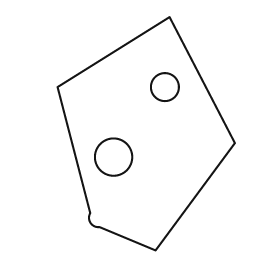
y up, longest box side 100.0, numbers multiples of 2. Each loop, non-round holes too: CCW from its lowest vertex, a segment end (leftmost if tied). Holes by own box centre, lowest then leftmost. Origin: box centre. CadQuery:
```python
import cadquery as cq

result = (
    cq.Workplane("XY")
    .moveTo(4.0, -50.0)
    .lineTo(38.0, -4.0)
    .lineTo(10.0, 50.0)
    .lineTo(-38.0, 20.0)
    .lineTo(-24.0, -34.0)
    .threePointArc((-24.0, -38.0), (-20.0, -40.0))
    .close()
    .moveTo(-14.0, -10.0)
    .circle(8.0)
    .moveTo(8.0, 20.0)
    .circle(6.0)
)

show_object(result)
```